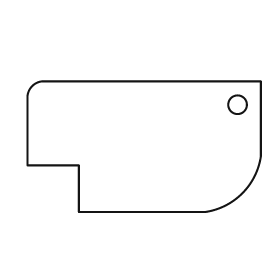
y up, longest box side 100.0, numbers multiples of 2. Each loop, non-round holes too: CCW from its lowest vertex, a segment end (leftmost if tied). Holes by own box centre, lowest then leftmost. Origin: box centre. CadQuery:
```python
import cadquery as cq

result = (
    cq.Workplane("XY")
    .moveTo(-28.0, -28.0)
    .lineTo(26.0, -28.0)
    .threePointArc((42.0, -20.0), (50.0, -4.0))
    .lineTo(50.0, 28.0)
    .lineTo(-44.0, 28.0)
    .threePointArc((-48.0, 26.0), (-50.0, 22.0))
    .lineTo(-50.0, -8.0)
    .lineTo(-28.0, -8.0)
    .close()
    .moveTo(40.0, 18.0)
    .circle(4.0)
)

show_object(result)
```